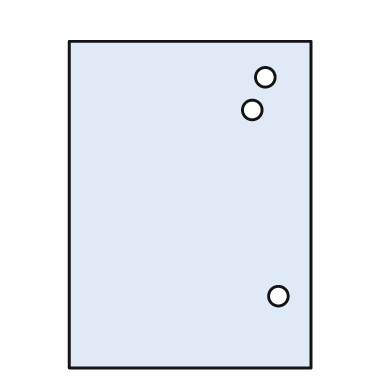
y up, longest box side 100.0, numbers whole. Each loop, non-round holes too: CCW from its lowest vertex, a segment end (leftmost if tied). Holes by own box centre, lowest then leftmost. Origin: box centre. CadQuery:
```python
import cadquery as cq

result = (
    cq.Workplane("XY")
    .moveTo(-37.0, -50.0)
    .lineTo(37.0, -50.0)
    .lineTo(37.0, 50.0)
    .lineTo(-37.0, 50.0)
    .close()
    .moveTo(27.0, -28.0)
    .circle(3.0)
    .moveTo(19.0, 29.0)
    .circle(3.0)
    .moveTo(23.0, 39.0)
    .circle(3.0)
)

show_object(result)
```